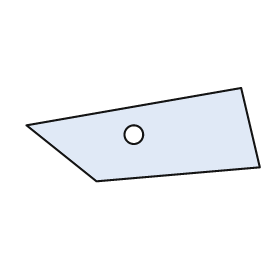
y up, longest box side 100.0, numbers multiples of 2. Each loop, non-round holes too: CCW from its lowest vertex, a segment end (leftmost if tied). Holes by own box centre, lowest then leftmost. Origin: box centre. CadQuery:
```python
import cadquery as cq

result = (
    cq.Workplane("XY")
    .moveTo(-20.0, -20.0)
    .lineTo(50.0, -14.0)
    .lineTo(42.0, 20.0)
    .lineTo(-50.0, 4.0)
    .close()
    .moveTo(-4.0, 0.0)
    .circle(4.0)
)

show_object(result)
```